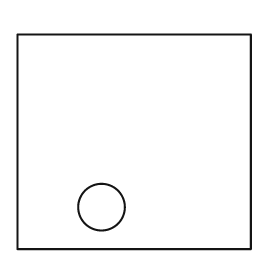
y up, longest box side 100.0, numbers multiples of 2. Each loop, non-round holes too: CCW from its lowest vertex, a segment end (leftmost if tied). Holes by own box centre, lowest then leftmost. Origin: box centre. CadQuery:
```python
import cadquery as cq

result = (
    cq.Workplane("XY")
    .moveTo(-50.0, -46.0)
    .lineTo(50.0, -46.0)
    .lineTo(50.0, 46.0)
    .lineTo(-50.0, 46.0)
    .close()
    .moveTo(-14.0, -28.0)
    .circle(10.0)
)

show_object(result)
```